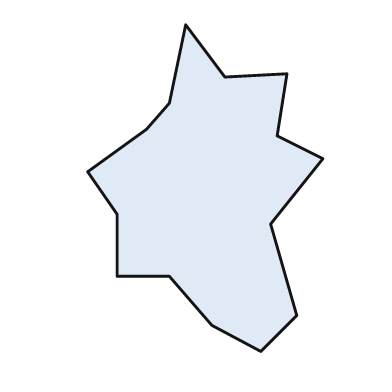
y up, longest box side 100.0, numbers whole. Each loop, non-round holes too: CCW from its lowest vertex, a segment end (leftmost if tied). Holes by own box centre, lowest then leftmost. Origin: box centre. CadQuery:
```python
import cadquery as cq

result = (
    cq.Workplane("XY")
    .moveTo(17.0, -50.0)
    .lineTo(28.0, -39.0)
    .lineTo(20.0, -11.0)
    .lineTo(36.0, 9.0)
    .lineTo(22.0, 16.0)
    .lineTo(25.0, 35.0)
    .lineTo(6.0, 34.0)
    .lineTo(-6.0, 50.0)
    .lineTo(-11.0, 26.0)
    .lineTo(-18.0, 18.0)
    .lineTo(-36.0, 5.0)
    .lineTo(-27.0, -8.0)
    .lineTo(-27.0, -27.0)
    .lineTo(-11.0, -27.0)
    .lineTo(2.0, -42.0)
    .close()
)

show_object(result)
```